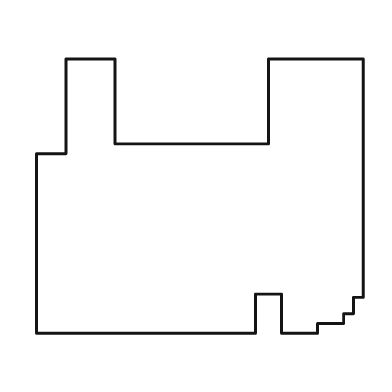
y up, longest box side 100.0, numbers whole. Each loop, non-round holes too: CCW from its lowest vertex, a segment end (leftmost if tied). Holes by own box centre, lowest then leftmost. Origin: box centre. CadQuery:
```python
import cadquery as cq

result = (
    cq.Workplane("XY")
    .moveTo(-50.0, -42.0)
    .lineTo(17.0, -42.0)
    .lineTo(17.0, -30.0)
    .lineTo(25.0, -30.0)
    .lineTo(25.0, -42.0)
    .lineTo(36.0, -42.0)
    .lineTo(36.0, -39.0)
    .lineTo(44.0, -39.0)
    .lineTo(44.0, -36.0)
    .lineTo(47.0, -36.0)
    .lineTo(47.0, -31.0)
    .lineTo(50.0, -31.0)
    .lineTo(50.0, 42.0)
    .lineTo(21.0, 42.0)
    .lineTo(21.0, 16.0)
    .lineTo(-26.0, 16.0)
    .lineTo(-26.0, 42.0)
    .lineTo(-41.0, 42.0)
    .lineTo(-41.0, 13.0)
    .lineTo(-50.0, 13.0)
    .close()
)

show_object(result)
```